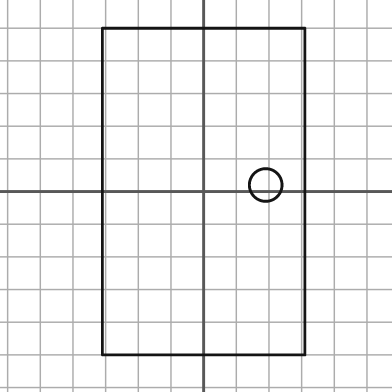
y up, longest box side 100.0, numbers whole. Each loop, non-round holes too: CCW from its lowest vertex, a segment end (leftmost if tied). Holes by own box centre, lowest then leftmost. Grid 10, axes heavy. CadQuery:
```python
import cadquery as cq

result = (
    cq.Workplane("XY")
    .moveTo(-31.0, -50.0)
    .lineTo(31.0, -50.0)
    .lineTo(31.0, 50.0)
    .lineTo(-31.0, 50.0)
    .close()
    .moveTo(19.0, 2.0)
    .circle(5.0)
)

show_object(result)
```